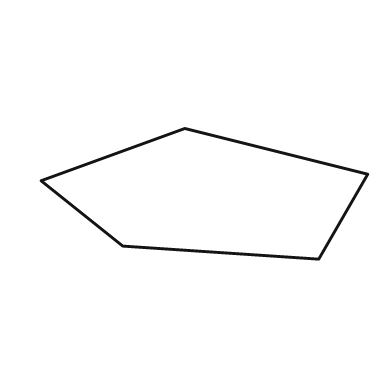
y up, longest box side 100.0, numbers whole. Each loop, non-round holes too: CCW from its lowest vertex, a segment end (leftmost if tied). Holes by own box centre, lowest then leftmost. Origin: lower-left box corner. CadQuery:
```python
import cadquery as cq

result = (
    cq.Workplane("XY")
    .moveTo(85.0, 0.0)
    .lineTo(100.0, 26.0)
    .lineTo(44.0, 40.0)
    .lineTo(0.0, 24.0)
    .lineTo(25.0, 4.0)
    .close()
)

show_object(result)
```